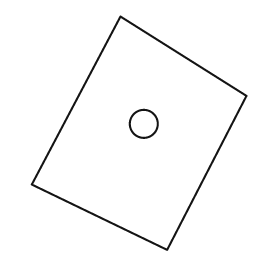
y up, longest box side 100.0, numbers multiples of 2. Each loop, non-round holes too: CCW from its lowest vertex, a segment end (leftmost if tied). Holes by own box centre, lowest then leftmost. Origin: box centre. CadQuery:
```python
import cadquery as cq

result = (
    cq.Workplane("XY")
    .moveTo(12.0, -50.0)
    .lineTo(46.0, 16.0)
    .lineTo(-8.0, 50.0)
    .lineTo(-46.0, -22.0)
    .close()
    .moveTo(2.0, 4.0)
    .circle(6.0)
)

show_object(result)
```